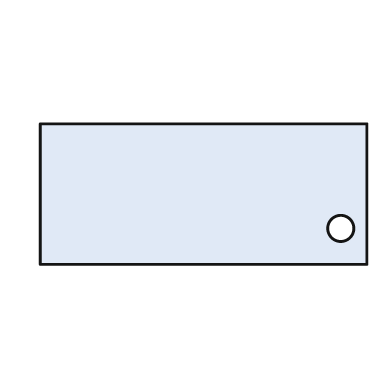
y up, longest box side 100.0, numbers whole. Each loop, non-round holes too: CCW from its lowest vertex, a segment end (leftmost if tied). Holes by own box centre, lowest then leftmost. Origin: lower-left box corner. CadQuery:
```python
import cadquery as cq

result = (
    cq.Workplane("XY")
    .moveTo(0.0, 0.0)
    .lineTo(100.0, 0.0)
    .lineTo(100.0, 43.0)
    .lineTo(0.0, 43.0)
    .close()
    .moveTo(92.0, 11.0)
    .circle(4.0)
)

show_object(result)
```